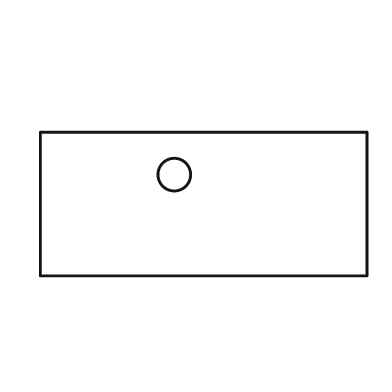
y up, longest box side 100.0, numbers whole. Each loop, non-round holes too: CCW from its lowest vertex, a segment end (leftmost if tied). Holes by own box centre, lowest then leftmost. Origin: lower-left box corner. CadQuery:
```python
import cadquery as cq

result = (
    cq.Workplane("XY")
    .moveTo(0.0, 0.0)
    .lineTo(100.0, 0.0)
    .lineTo(100.0, 44.0)
    .lineTo(0.0, 44.0)
    .close()
    .moveTo(41.0, 31.0)
    .circle(5.0)
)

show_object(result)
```